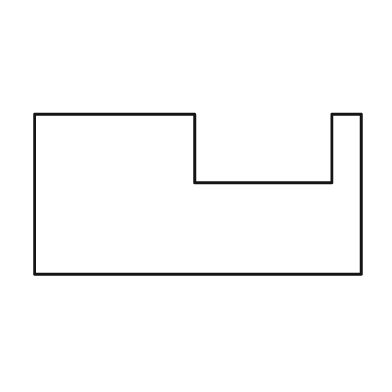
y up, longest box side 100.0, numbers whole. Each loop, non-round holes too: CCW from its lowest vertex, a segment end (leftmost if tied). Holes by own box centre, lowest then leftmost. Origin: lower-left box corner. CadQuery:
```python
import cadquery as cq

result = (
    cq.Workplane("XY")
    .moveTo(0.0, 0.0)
    .lineTo(100.0, 0.0)
    .lineTo(100.0, 49.0)
    .lineTo(91.0, 49.0)
    .lineTo(91.0, 28.0)
    .lineTo(49.0, 28.0)
    .lineTo(49.0, 49.0)
    .lineTo(0.0, 49.0)
    .close()
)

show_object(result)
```